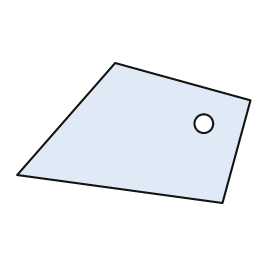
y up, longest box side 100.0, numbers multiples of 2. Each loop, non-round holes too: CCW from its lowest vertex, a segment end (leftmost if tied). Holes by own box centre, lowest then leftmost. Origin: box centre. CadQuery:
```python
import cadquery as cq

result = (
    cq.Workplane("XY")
    .moveTo(38.0, -30.0)
    .lineTo(50.0, 14.0)
    .lineTo(-8.0, 30.0)
    .lineTo(-50.0, -18.0)
    .close()
    .moveTo(30.0, 4.0)
    .circle(4.0)
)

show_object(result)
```